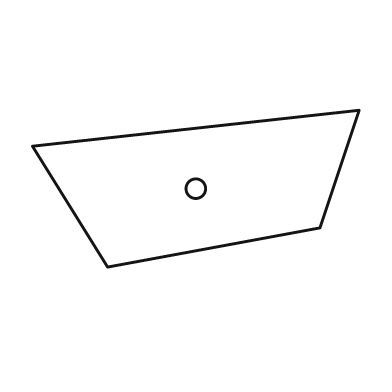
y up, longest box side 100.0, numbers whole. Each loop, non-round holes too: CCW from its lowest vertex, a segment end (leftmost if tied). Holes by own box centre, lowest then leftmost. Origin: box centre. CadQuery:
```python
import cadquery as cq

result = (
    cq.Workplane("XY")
    .moveTo(-27.0, -24.0)
    .lineTo(38.0, -12.0)
    .lineTo(50.0, 24.0)
    .lineTo(-50.0, 13.0)
    .close()
    .moveTo(0.0, 0.0)
    .circle(3.0)
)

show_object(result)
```